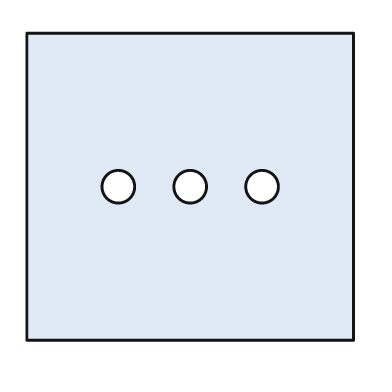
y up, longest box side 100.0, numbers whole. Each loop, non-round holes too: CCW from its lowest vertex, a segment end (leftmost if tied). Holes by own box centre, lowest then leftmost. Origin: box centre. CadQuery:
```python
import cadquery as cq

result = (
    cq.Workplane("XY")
    .moveTo(-50.0, -47.0)
    .lineTo(50.0, -47.0)
    .lineTo(50.0, 47.0)
    .lineTo(-50.0, 47.0)
    .close()
    .moveTo(-22.0, 0.0)
    .circle(5.0)
    .moveTo(0.0, 0.0)
    .circle(5.0)
    .moveTo(22.0, 0.0)
    .circle(5.0)
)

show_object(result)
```